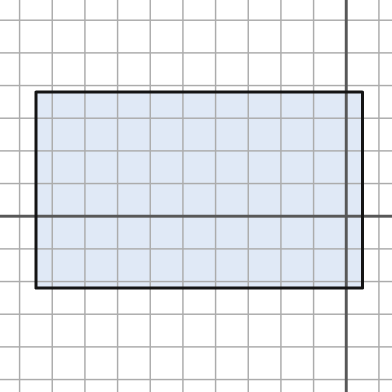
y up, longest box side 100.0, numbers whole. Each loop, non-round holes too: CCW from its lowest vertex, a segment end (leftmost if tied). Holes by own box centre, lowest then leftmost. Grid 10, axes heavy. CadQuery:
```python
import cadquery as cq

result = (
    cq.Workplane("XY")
    .moveTo(-95.0, -22.0)
    .lineTo(5.0, -22.0)
    .lineTo(5.0, 38.0)
    .lineTo(-95.0, 38.0)
    .close()
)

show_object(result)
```